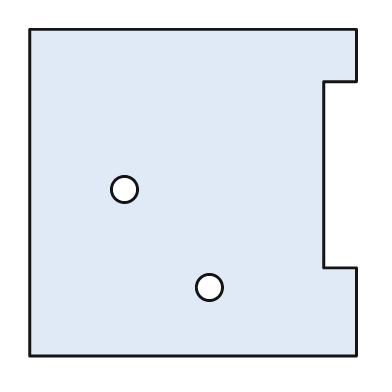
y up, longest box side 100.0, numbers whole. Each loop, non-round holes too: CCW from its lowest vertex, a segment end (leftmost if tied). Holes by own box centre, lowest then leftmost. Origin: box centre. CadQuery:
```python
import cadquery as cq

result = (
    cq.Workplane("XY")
    .moveTo(-50.0, -50.0)
    .lineTo(50.0, -50.0)
    .lineTo(50.0, -23.0)
    .lineTo(40.0, -23.0)
    .lineTo(40.0, 34.0)
    .lineTo(50.0, 34.0)
    .lineTo(50.0, 50.0)
    .lineTo(-50.0, 50.0)
    .close()
    .moveTo(5.0, -29.0)
    .circle(4.0)
    .moveTo(-21.0, 1.0)
    .circle(4.0)
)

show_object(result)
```